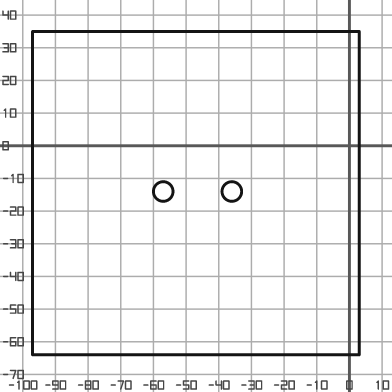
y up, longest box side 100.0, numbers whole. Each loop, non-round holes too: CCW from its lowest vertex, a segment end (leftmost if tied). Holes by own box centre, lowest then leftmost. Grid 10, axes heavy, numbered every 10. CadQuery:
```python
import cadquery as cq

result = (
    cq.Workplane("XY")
    .moveTo(-97.0, -64.0)
    .lineTo(3.0, -64.0)
    .lineTo(3.0, 35.0)
    .lineTo(-97.0, 35.0)
    .close()
    .moveTo(-57.0, -14.0)
    .circle(3.0)
    .moveTo(-36.0, -14.0)
    .circle(3.0)
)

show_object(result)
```